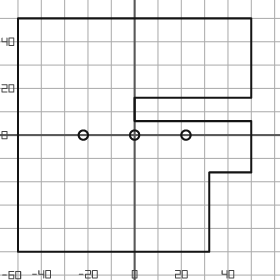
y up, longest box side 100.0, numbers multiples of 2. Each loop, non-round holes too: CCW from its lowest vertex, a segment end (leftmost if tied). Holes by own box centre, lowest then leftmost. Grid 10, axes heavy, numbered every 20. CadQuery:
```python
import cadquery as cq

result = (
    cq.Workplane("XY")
    .moveTo(-50.0, -50.0)
    .lineTo(32.0, -50.0)
    .lineTo(32.0, -16.0)
    .lineTo(50.0, -16.0)
    .lineTo(50.0, 6.0)
    .lineTo(0.0, 6.0)
    .lineTo(0.0, 16.0)
    .lineTo(50.0, 16.0)
    .lineTo(50.0, 50.0)
    .lineTo(-50.0, 50.0)
    .close()
    .moveTo(-22.0, 0.0)
    .circle(2.0)
    .moveTo(0.0, 0.0)
    .circle(2.0)
    .moveTo(22.0, 0.0)
    .circle(2.0)
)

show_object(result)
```